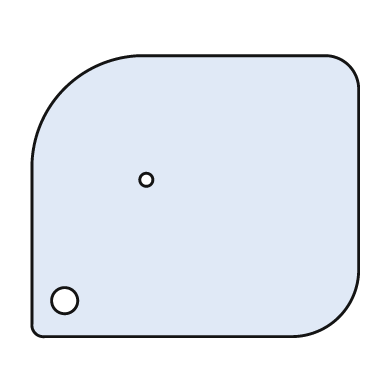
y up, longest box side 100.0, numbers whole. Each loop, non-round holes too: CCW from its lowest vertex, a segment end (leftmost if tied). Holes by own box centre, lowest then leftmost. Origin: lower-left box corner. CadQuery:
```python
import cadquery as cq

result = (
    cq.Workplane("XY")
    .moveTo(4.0, 0.0)
    .lineTo(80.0, 0.0)
    .threePointArc((94.0, 6.0), (100.0, 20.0))
    .lineTo(100.0, 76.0)
    .threePointArc((97.0, 83.0), (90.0, 86.0))
    .lineTo(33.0, 86.0)
    .threePointArc((10.0, 76.0), (0.0, 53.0))
    .lineTo(0.0, 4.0)
    .threePointArc((1.0, 1.0), (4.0, 0.0))
    .close()
    .moveTo(10.0, 11.0)
    .circle(4.0)
    .moveTo(35.0, 48.0)
    .circle(2.0)
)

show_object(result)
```